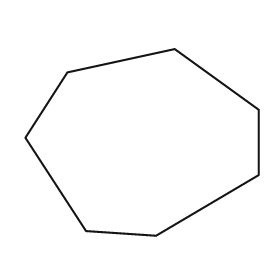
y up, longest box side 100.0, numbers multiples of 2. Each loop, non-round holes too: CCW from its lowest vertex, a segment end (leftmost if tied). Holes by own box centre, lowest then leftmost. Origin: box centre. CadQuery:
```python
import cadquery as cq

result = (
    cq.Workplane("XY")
    .moveTo(6.0, -40.0)
    .lineTo(50.0, -14.0)
    .lineTo(50.0, 14.0)
    .lineTo(14.0, 40.0)
    .lineTo(-32.0, 30.0)
    .lineTo(-50.0, 2.0)
    .lineTo(-24.0, -38.0)
    .close()
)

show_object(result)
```